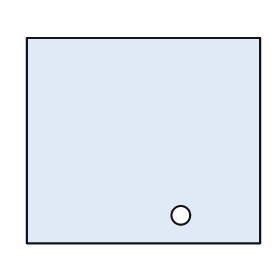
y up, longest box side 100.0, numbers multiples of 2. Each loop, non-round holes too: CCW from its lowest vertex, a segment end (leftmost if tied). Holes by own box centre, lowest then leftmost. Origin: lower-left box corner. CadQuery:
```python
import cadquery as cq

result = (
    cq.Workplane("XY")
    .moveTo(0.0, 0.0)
    .lineTo(100.0, 0.0)
    .lineTo(100.0, 88.0)
    .lineTo(0.0, 88.0)
    .close()
    .moveTo(66.0, 12.0)
    .circle(4.0)
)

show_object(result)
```